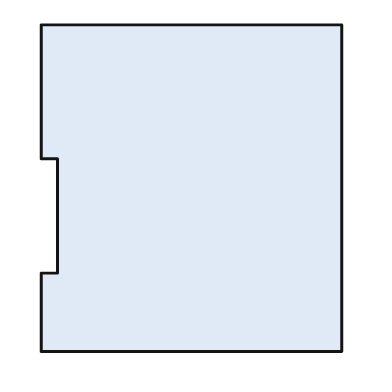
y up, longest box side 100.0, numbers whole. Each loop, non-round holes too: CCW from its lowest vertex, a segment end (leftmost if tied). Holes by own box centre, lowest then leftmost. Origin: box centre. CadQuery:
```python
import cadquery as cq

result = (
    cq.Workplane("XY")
    .moveTo(-46.0, -50.0)
    .lineTo(46.0, -50.0)
    .lineTo(46.0, 50.0)
    .lineTo(-46.0, 50.0)
    .lineTo(-46.0, 9.0)
    .lineTo(-41.0, 9.0)
    .lineTo(-41.0, -26.0)
    .lineTo(-46.0, -26.0)
    .close()
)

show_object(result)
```